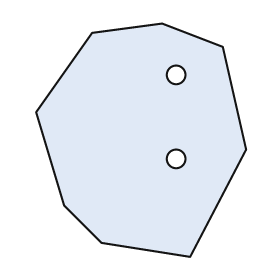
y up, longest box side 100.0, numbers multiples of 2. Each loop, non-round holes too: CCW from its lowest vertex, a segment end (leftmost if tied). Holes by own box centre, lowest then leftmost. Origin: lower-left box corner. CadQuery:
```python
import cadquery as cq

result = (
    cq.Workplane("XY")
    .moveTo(66.0, 0.0)
    .lineTo(90.0, 46.0)
    .lineTo(80.0, 90.0)
    .lineTo(54.0, 100.0)
    .lineTo(24.0, 96.0)
    .lineTo(0.0, 62.0)
    .lineTo(12.0, 22.0)
    .lineTo(28.0, 6.0)
    .close()
    .moveTo(60.0, 42.0)
    .circle(4.0)
    .moveTo(60.0, 78.0)
    .circle(4.0)
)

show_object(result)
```